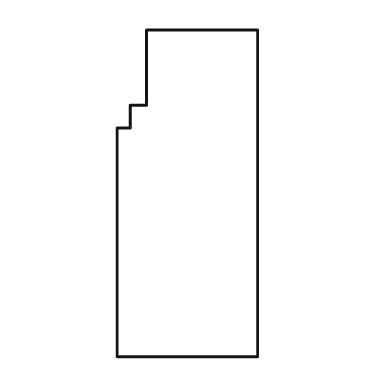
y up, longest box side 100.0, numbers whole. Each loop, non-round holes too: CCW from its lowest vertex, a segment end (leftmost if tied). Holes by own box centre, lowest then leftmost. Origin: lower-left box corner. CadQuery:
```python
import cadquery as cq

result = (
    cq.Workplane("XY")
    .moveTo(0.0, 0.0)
    .lineTo(43.0, 0.0)
    .lineTo(43.0, 100.0)
    .lineTo(9.0, 100.0)
    .lineTo(9.0, 77.0)
    .lineTo(4.0, 77.0)
    .lineTo(4.0, 70.0)
    .lineTo(0.0, 70.0)
    .close()
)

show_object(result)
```